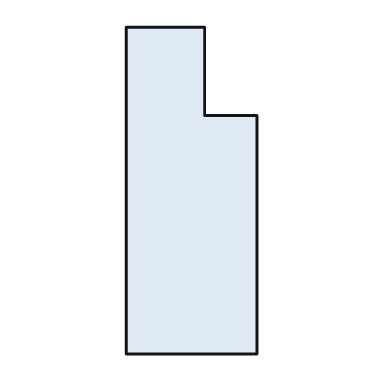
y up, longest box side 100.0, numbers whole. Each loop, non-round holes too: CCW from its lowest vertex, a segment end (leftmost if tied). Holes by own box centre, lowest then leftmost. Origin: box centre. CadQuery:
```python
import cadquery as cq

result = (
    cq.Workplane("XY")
    .moveTo(-20.0, -50.0)
    .lineTo(20.0, -50.0)
    .lineTo(20.0, 23.0)
    .lineTo(4.0, 23.0)
    .lineTo(4.0, 50.0)
    .lineTo(-20.0, 50.0)
    .close()
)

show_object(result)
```